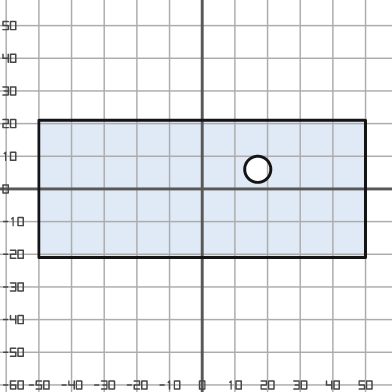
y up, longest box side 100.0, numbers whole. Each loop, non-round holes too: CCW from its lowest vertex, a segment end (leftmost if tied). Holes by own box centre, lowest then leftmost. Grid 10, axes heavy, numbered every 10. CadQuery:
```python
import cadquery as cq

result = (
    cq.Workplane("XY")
    .moveTo(-50.0, -21.0)
    .lineTo(50.0, -21.0)
    .lineTo(50.0, 21.0)
    .lineTo(-50.0, 21.0)
    .close()
    .moveTo(17.0, 6.0)
    .circle(4.0)
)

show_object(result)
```